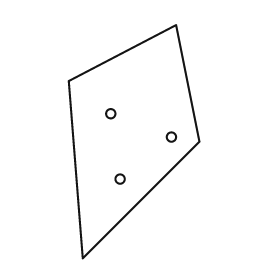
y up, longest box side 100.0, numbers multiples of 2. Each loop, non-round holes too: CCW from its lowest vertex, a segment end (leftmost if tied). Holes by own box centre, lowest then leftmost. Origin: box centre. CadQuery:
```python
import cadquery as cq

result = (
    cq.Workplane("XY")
    .moveTo(-22.0, -50.0)
    .lineTo(28.0, 0.0)
    .lineTo(18.0, 50.0)
    .lineTo(-28.0, 26.0)
    .close()
    .moveTo(-6.0, -16.0)
    .circle(2.0)
    .moveTo(16.0, 2.0)
    .circle(2.0)
    .moveTo(-10.0, 12.0)
    .circle(2.0)
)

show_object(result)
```